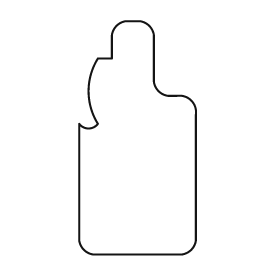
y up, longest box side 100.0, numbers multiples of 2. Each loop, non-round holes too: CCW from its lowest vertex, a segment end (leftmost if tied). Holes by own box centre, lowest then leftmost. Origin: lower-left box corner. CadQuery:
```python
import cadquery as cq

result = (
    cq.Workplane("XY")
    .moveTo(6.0, 0.0)
    .lineTo(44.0, 0.0)
    .threePointArc((48.0, 2.0), (50.0, 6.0))
    .lineTo(50.0, 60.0)
    .threePointArc((48.0, 66.0), (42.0, 68.0))
    .lineTo(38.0, 68.0)
    .threePointArc((34.0, 70.0), (32.0, 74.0))
    .lineTo(32.0, 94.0)
    .threePointArc((30.0, 98.0), (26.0, 100.0))
    .lineTo(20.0, 100.0)
    .threePointArc((16.0, 98.0), (14.0, 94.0))
    .lineTo(14.0, 84.0)
    .lineTo(8.0, 84.0)
    .threePointArc((4.0, 70.0), (8.0, 56.0))
    .threePointArc((4.0, 54.0), (0.0, 56.0))
    .lineTo(0.0, 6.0)
    .threePointArc((2.0, 2.0), (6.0, 0.0))
    .close()
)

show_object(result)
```